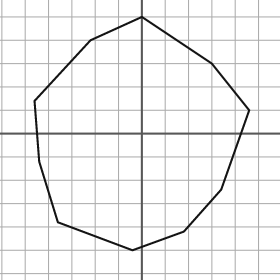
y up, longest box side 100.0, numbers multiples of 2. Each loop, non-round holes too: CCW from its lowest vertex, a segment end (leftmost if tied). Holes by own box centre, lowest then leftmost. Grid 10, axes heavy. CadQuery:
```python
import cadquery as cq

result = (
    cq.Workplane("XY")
    .moveTo(-4.0, -50.0)
    .lineTo(18.0, -42.0)
    .lineTo(34.0, -24.0)
    .lineTo(46.0, 10.0)
    .lineTo(30.0, 30.0)
    .lineTo(0.0, 50.0)
    .lineTo(-22.0, 40.0)
    .lineTo(-46.0, 14.0)
    .lineTo(-44.0, -12.0)
    .lineTo(-36.0, -38.0)
    .close()
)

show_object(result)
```